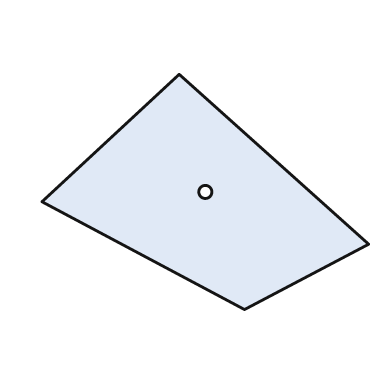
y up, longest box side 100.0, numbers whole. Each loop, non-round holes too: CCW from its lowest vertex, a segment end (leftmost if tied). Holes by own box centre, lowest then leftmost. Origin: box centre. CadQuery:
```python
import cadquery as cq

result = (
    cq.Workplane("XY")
    .moveTo(12.0, -36.0)
    .lineTo(50.0, -16.0)
    .lineTo(-8.0, 36.0)
    .lineTo(-50.0, -3.0)
    .close()
    .moveTo(0.0, 0.0)
    .circle(2.0)
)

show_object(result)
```